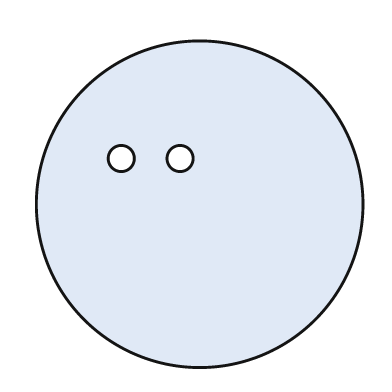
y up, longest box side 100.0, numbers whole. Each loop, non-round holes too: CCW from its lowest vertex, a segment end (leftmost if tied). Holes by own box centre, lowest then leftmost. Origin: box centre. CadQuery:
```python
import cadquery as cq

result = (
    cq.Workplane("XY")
    .moveTo(0.0, 0.0)
    .circle(50.0)
    .moveTo(-24.0, 14.0)
    .circle(4.0)
    .moveTo(-6.0, 14.0)
    .circle(4.0)
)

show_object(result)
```